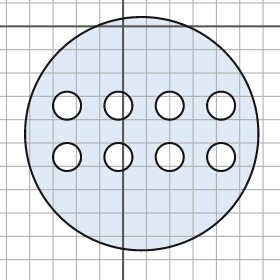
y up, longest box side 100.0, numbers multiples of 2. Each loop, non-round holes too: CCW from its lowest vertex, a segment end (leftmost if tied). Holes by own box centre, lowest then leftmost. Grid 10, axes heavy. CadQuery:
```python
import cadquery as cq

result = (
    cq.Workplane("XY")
    .moveTo(8.0, -46.0)
    .circle(50.0)
    .moveTo(-24.0, -56.0)
    .circle(6.0)
    .moveTo(-2.0, -56.0)
    .circle(6.0)
    .moveTo(20.0, -56.0)
    .circle(6.0)
    .moveTo(42.0, -56.0)
    .circle(6.0)
    .moveTo(-24.0, -34.0)
    .circle(6.0)
    .moveTo(-2.0, -34.0)
    .circle(6.0)
    .moveTo(20.0, -34.0)
    .circle(6.0)
    .moveTo(42.0, -34.0)
    .circle(6.0)
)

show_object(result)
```